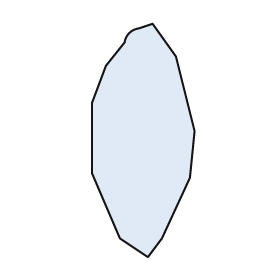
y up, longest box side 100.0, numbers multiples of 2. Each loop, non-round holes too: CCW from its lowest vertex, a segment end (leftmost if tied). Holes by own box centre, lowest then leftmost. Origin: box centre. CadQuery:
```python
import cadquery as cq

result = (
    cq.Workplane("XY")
    .moveTo(2.0, -50.0)
    .lineTo(8.0, -42.0)
    .lineTo(20.0, -16.0)
    .lineTo(22.0, 4.0)
    .lineTo(14.0, 36.0)
    .lineTo(4.0, 50.0)
    .lineTo(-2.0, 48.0)
    .threePointArc((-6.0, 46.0), (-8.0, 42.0))
    .lineTo(-16.0, 32.0)
    .lineTo(-22.0, 16.0)
    .lineTo(-22.0, -14.0)
    .lineTo(-10.0, -42.0)
    .close()
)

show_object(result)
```